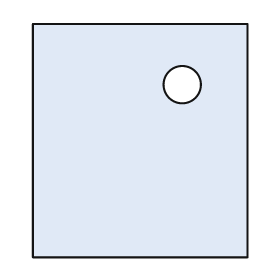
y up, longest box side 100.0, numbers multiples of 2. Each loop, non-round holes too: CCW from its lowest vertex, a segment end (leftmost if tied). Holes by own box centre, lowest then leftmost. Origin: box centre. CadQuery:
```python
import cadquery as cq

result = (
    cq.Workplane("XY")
    .moveTo(-46.0, -50.0)
    .lineTo(46.0, -50.0)
    .lineTo(46.0, 50.0)
    .lineTo(-46.0, 50.0)
    .close()
    .moveTo(18.0, 24.0)
    .circle(8.0)
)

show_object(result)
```